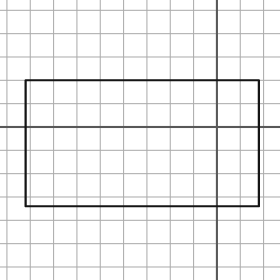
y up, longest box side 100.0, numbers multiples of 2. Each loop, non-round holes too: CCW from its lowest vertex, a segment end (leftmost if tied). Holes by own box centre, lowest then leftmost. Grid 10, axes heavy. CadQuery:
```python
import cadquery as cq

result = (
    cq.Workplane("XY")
    .moveTo(-82.0, -34.0)
    .lineTo(18.0, -34.0)
    .lineTo(18.0, 20.0)
    .lineTo(-82.0, 20.0)
    .close()
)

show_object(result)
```